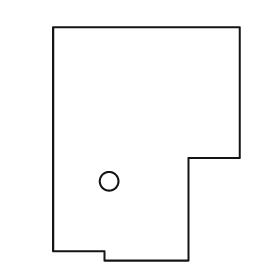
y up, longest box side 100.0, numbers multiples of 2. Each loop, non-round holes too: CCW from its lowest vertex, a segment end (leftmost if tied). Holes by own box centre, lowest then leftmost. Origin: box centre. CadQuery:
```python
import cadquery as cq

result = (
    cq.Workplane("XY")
    .moveTo(-18.0, -50.0)
    .lineTo(18.0, -50.0)
    .lineTo(18.0, -6.0)
    .lineTo(40.0, -6.0)
    .lineTo(40.0, 50.0)
    .lineTo(-40.0, 50.0)
    .lineTo(-40.0, -46.0)
    .lineTo(-18.0, -46.0)
    .close()
    .moveTo(-16.0, -16.0)
    .circle(4.0)
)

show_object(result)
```